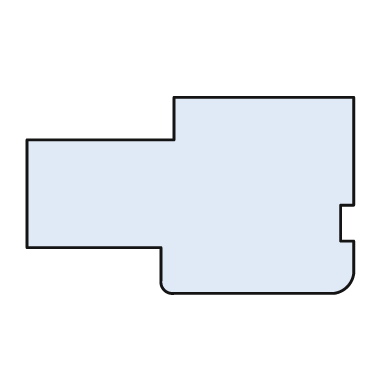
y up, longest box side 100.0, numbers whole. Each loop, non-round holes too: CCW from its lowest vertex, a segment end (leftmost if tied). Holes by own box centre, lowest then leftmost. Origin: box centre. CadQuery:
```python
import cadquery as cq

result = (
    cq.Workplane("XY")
    .moveTo(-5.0, -30.0)
    .lineTo(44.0, -30.0)
    .threePointArc((48.0, -28.0), (50.0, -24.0))
    .lineTo(50.0, -14.0)
    .lineTo(46.0, -14.0)
    .lineTo(46.0, -3.0)
    .lineTo(50.0, -3.0)
    .lineTo(50.0, 30.0)
    .lineTo(-5.0, 30.0)
    .lineTo(-5.0, 17.0)
    .lineTo(-50.0, 17.0)
    .lineTo(-50.0, -16.0)
    .lineTo(-9.0, -16.0)
    .lineTo(-9.0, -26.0)
    .threePointArc((-8.0, -29.0), (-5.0, -30.0))
    .close()
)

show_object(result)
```